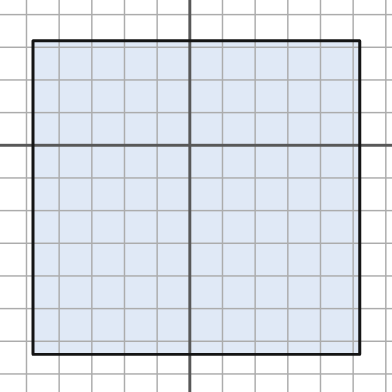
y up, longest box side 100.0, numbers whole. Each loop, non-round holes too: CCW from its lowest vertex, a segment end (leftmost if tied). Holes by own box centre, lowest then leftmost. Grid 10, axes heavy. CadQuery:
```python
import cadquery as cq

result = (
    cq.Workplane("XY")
    .moveTo(-48.0, -64.0)
    .lineTo(52.0, -64.0)
    .lineTo(52.0, 32.0)
    .lineTo(-48.0, 32.0)
    .close()
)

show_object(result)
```